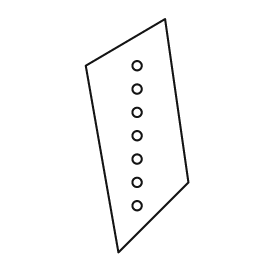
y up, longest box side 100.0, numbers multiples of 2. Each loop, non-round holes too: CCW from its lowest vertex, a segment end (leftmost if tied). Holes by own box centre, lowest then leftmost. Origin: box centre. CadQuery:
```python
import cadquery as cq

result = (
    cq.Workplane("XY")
    .moveTo(-8.0, -50.0)
    .lineTo(22.0, -20.0)
    .lineTo(12.0, 50.0)
    .lineTo(-22.0, 30.0)
    .close()
    .moveTo(0.0, -30.0)
    .circle(2.0)
    .moveTo(0.0, -20.0)
    .circle(2.0)
    .moveTo(0.0, -10.0)
    .circle(2.0)
    .moveTo(0.0, 0.0)
    .circle(2.0)
    .moveTo(0.0, 10.0)
    .circle(2.0)
    .moveTo(0.0, 20.0)
    .circle(2.0)
    .moveTo(0.0, 30.0)
    .circle(2.0)
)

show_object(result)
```